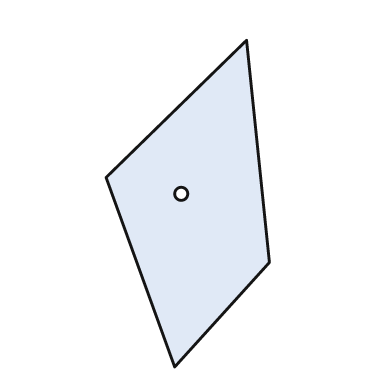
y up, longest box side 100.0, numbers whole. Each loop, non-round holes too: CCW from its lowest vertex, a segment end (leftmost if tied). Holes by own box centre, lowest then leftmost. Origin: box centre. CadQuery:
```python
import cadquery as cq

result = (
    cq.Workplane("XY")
    .moveTo(-4.0, -50.0)
    .lineTo(25.0, -18.0)
    .lineTo(18.0, 50.0)
    .lineTo(-25.0, 8.0)
    .close()
    .moveTo(-2.0, 3.0)
    .circle(2.0)
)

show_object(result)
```